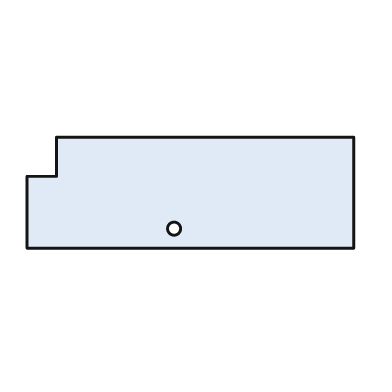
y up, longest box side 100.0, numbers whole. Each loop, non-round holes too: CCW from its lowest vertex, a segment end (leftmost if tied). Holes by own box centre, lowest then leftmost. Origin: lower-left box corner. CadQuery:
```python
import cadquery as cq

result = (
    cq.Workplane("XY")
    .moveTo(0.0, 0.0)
    .lineTo(100.0, 0.0)
    .lineTo(100.0, 34.0)
    .lineTo(9.0, 34.0)
    .lineTo(9.0, 22.0)
    .lineTo(0.0, 22.0)
    .close()
    .moveTo(45.0, 6.0)
    .circle(2.0)
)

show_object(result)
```